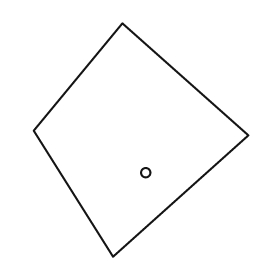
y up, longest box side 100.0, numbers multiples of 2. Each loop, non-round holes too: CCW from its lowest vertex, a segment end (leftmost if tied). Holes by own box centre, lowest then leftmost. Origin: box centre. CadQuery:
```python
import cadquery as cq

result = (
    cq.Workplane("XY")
    .moveTo(-12.0, -50.0)
    .lineTo(46.0, 2.0)
    .lineTo(-8.0, 50.0)
    .lineTo(-46.0, 4.0)
    .close()
    .moveTo(2.0, -14.0)
    .circle(2.0)
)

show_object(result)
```